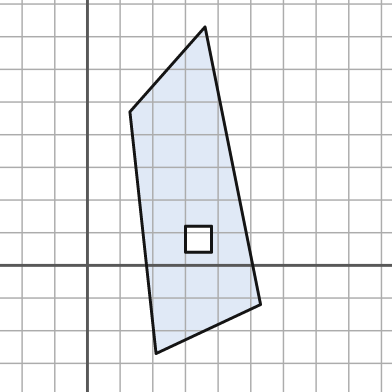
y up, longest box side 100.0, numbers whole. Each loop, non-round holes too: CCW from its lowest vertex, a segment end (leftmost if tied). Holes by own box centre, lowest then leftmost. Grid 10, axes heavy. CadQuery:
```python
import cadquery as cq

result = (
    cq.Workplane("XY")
    .moveTo(21.0, -27.0)
    .lineTo(53.0, -12.0)
    .lineTo(36.0, 73.0)
    .lineTo(13.0, 47.0)
    .close()
    .moveTo(30.0, 4.0)
    .lineTo(38.0, 4.0)
    .lineTo(38.0, 12.0)
    .lineTo(30.0, 12.0)
    .close()
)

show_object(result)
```